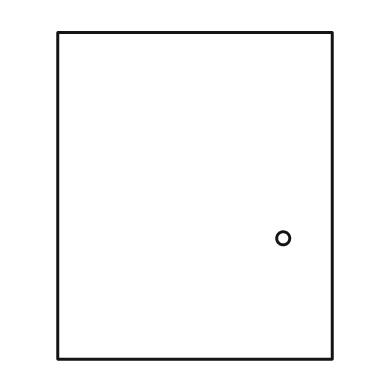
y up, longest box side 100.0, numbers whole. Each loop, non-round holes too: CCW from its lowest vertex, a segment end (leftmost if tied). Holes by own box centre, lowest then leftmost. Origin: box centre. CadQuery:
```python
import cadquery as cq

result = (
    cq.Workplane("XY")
    .moveTo(-42.0, -50.0)
    .lineTo(42.0, -50.0)
    .lineTo(42.0, 50.0)
    .lineTo(-42.0, 50.0)
    .close()
    .moveTo(27.0, -13.0)
    .circle(2.0)
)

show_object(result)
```